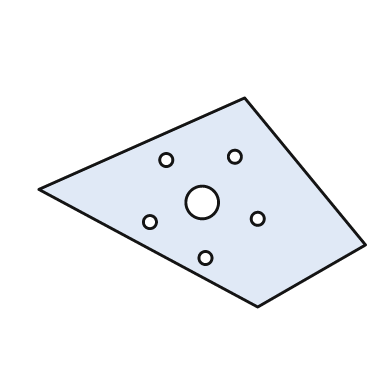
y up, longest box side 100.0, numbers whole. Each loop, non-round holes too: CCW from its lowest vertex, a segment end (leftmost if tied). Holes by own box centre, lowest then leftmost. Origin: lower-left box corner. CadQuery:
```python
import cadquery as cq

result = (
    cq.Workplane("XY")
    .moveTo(67.0, 0.0)
    .lineTo(100.0, 19.0)
    .lineTo(63.0, 64.0)
    .lineTo(0.0, 36.0)
    .close()
    .moveTo(51.0, 15.0)
    .circle(2.0)
    .moveTo(34.0, 26.0)
    .circle(2.0)
    .moveTo(67.0, 27.0)
    .circle(2.0)
    .moveTo(50.0, 32.0)
    .circle(5.0)
    .moveTo(39.0, 45.0)
    .circle(2.0)
    .moveTo(60.0, 46.0)
    .circle(2.0)
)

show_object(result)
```